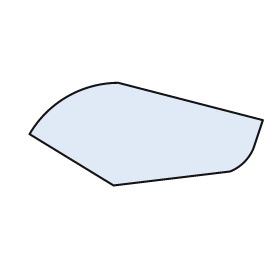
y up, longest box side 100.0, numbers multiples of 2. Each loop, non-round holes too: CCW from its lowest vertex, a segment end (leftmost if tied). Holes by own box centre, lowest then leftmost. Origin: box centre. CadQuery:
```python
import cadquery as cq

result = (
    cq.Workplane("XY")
    .moveTo(-14.0, -22.0)
    .lineTo(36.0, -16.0)
    .threePointArc((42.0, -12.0), (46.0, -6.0))
    .lineTo(50.0, 6.0)
    .lineTo(-12.0, 22.0)
    .threePointArc((-34.0, 16.0), (-50.0, 0.0))
    .close()
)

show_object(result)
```